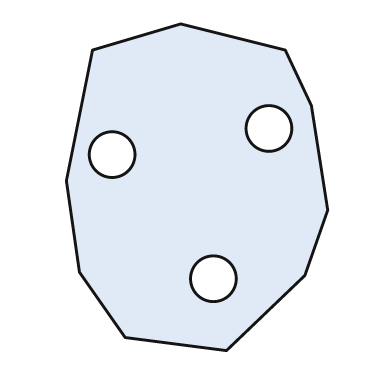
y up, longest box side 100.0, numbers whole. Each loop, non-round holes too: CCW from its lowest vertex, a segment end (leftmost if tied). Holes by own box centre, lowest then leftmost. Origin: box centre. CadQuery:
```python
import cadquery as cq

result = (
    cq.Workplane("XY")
    .moveTo(9.0, -50.0)
    .lineTo(33.0, -27.0)
    .lineTo(40.0, -7.0)
    .lineTo(35.0, 25.0)
    .lineTo(27.0, 42.0)
    .lineTo(-5.0, 50.0)
    .lineTo(-32.0, 42.0)
    .lineTo(-40.0, 2.0)
    .lineTo(-36.0, -26.0)
    .lineTo(-22.0, -46.0)
    .close()
    .moveTo(5.0, -28.0)
    .circle(7.0)
    .moveTo(-26.0, 10.0)
    .circle(7.0)
    .moveTo(22.0, 18.0)
    .circle(7.0)
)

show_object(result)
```